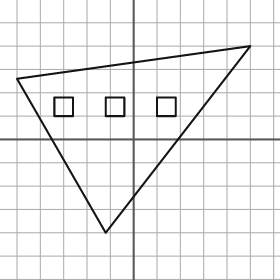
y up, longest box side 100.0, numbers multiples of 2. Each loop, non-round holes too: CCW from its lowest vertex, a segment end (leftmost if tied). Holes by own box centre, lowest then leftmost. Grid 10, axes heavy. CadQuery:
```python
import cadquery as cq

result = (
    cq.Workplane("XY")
    .moveTo(-12.0, -40.0)
    .lineTo(50.0, 40.0)
    .lineTo(-50.0, 26.0)
    .close()
    .moveTo(-34.0, 10.0)
    .lineTo(-26.0, 10.0)
    .lineTo(-26.0, 18.0)
    .lineTo(-34.0, 18.0)
    .close()
    .moveTo(-12.0, 10.0)
    .lineTo(-4.0, 10.0)
    .lineTo(-4.0, 18.0)
    .lineTo(-12.0, 18.0)
    .close()
    .moveTo(10.0, 10.0)
    .lineTo(18.0, 10.0)
    .lineTo(18.0, 18.0)
    .lineTo(10.0, 18.0)
    .close()
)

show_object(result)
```